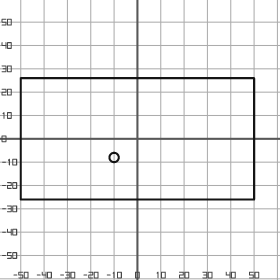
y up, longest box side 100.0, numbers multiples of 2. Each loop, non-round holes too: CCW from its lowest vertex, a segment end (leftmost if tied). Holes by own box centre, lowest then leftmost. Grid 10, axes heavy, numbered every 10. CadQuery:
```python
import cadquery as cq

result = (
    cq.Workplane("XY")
    .moveTo(-50.0, -26.0)
    .lineTo(50.0, -26.0)
    .lineTo(50.0, 26.0)
    .lineTo(-50.0, 26.0)
    .close()
    .moveTo(-10.0, -8.0)
    .circle(2.0)
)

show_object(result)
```